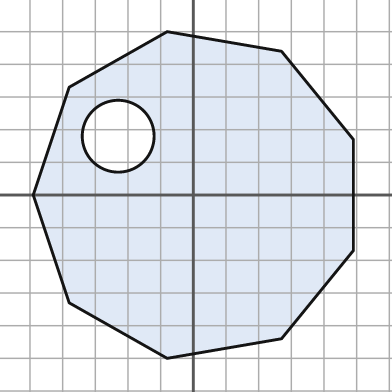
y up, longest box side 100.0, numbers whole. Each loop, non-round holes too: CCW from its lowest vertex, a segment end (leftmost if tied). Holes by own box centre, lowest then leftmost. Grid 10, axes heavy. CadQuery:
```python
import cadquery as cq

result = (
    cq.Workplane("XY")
    .moveTo(-8.0, -50.0)
    .lineTo(27.0, -44.0)
    .lineTo(49.0, -17.0)
    .lineTo(49.0, 17.0)
    .lineTo(27.0, 44.0)
    .lineTo(-8.0, 50.0)
    .lineTo(-38.0, 33.0)
    .lineTo(-49.0, 0.0)
    .lineTo(-38.0, -33.0)
    .close()
    .moveTo(-23.0, 18.0)
    .circle(11.0)
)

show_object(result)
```